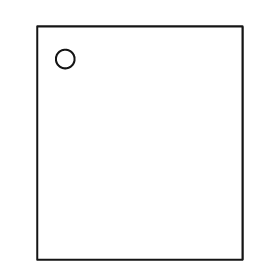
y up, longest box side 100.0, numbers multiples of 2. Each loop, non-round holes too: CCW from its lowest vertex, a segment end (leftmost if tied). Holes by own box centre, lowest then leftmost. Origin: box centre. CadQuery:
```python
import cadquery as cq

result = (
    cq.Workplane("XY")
    .moveTo(-44.0, -50.0)
    .lineTo(44.0, -50.0)
    .lineTo(44.0, 50.0)
    .lineTo(-44.0, 50.0)
    .close()
    .moveTo(-32.0, 36.0)
    .circle(4.0)
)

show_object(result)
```